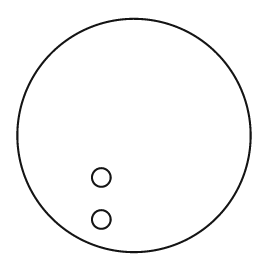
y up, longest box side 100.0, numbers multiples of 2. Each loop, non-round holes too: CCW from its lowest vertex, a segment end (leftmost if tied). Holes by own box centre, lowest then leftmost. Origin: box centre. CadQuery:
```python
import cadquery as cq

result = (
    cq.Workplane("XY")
    .moveTo(0.0, 0.0)
    .circle(50.0)
    .moveTo(-14.0, -36.0)
    .circle(4.0)
    .moveTo(-14.0, -18.0)
    .circle(4.0)
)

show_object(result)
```